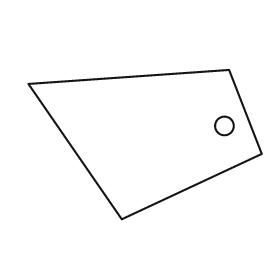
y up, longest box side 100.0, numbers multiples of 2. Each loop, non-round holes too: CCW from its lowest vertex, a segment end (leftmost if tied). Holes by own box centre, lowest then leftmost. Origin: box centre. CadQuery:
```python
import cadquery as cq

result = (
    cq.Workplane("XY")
    .moveTo(-10.0, -32.0)
    .lineTo(50.0, -4.0)
    .lineTo(36.0, 32.0)
    .lineTo(-50.0, 26.0)
    .close()
    .moveTo(34.0, 8.0)
    .circle(4.0)
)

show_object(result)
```